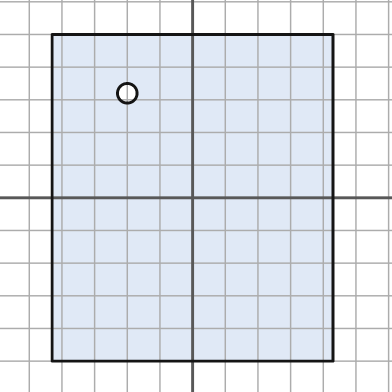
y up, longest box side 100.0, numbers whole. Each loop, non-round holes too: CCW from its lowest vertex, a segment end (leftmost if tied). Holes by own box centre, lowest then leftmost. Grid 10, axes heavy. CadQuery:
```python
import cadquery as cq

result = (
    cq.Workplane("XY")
    .moveTo(-43.0, -50.0)
    .lineTo(43.0, -50.0)
    .lineTo(43.0, 50.0)
    .lineTo(-43.0, 50.0)
    .close()
    .moveTo(-20.0, 32.0)
    .circle(3.0)
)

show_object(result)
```